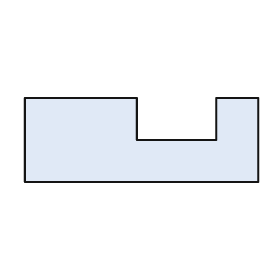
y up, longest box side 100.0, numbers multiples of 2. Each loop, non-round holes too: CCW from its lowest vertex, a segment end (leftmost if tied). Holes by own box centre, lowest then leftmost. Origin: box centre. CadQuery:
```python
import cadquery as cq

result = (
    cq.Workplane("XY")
    .moveTo(-50.0, -18.0)
    .lineTo(50.0, -18.0)
    .lineTo(50.0, 18.0)
    .lineTo(32.0, 18.0)
    .lineTo(32.0, 0.0)
    .lineTo(-2.0, 0.0)
    .lineTo(-2.0, 18.0)
    .lineTo(-50.0, 18.0)
    .close()
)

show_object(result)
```